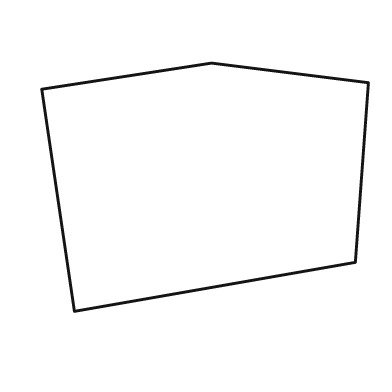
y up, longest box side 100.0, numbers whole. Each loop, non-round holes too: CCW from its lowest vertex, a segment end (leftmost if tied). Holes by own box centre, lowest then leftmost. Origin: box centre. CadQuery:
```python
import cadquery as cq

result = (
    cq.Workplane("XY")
    .moveTo(-40.0, -38.0)
    .lineTo(46.0, -23.0)
    .lineTo(50.0, 32.0)
    .lineTo(2.0, 38.0)
    .lineTo(-50.0, 30.0)
    .close()
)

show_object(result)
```